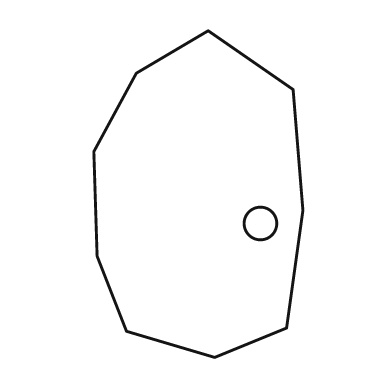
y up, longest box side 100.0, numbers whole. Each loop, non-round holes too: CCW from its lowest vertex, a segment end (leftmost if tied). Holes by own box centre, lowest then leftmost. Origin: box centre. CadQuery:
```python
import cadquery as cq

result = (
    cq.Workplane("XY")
    .moveTo(5.0, -50.0)
    .lineTo(27.0, -41.0)
    .lineTo(32.0, -5.0)
    .lineTo(29.0, 32.0)
    .lineTo(3.0, 50.0)
    .lineTo(-19.0, 37.0)
    .lineTo(-32.0, 13.0)
    .lineTo(-31.0, -19.0)
    .lineTo(-22.0, -42.0)
    .close()
    .moveTo(19.0, -9.0)
    .circle(5.0)
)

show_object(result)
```